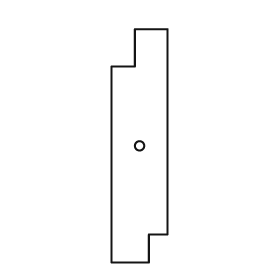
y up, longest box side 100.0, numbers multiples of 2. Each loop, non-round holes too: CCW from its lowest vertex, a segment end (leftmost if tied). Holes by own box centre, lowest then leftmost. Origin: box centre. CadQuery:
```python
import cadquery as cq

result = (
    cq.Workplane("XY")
    .moveTo(-12.0, -50.0)
    .lineTo(4.0, -50.0)
    .lineTo(4.0, -38.0)
    .lineTo(12.0, -38.0)
    .lineTo(12.0, 50.0)
    .lineTo(-2.0, 50.0)
    .lineTo(-2.0, 34.0)
    .lineTo(-12.0, 34.0)
    .close()
    .moveTo(0.0, 0.0)
    .circle(2.0)
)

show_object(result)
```